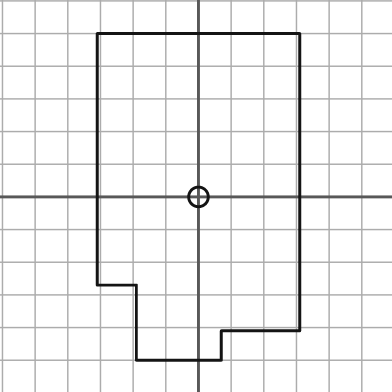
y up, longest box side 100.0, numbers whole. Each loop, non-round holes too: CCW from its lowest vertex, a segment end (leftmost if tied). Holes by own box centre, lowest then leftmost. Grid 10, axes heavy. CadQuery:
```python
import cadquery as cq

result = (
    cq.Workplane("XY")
    .moveTo(-19.0, -50.0)
    .lineTo(7.0, -50.0)
    .lineTo(7.0, -41.0)
    .lineTo(31.0, -41.0)
    .lineTo(31.0, 50.0)
    .lineTo(-31.0, 50.0)
    .lineTo(-31.0, -27.0)
    .lineTo(-19.0, -27.0)
    .close()
    .moveTo(0.0, 0.0)
    .circle(3.0)
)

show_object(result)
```